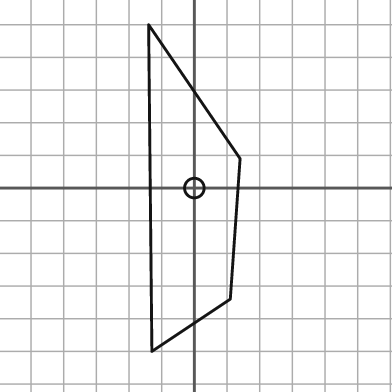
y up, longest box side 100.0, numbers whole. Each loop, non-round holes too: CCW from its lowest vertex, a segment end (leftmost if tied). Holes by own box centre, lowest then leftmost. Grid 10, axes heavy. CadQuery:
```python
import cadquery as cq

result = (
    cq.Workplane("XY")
    .moveTo(-13.0, -50.0)
    .lineTo(11.0, -34.0)
    .lineTo(14.0, 9.0)
    .lineTo(-14.0, 50.0)
    .close()
    .moveTo(0.0, 0.0)
    .circle(3.0)
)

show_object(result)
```